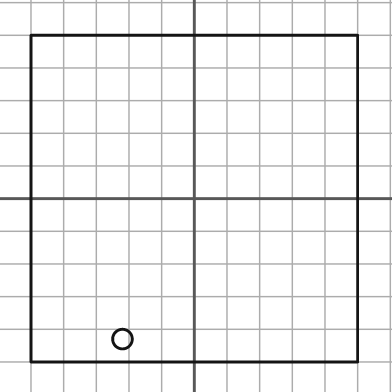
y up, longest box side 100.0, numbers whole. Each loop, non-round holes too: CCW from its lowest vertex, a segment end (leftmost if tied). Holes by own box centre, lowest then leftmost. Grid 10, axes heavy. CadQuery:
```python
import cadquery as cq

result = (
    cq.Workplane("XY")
    .moveTo(-50.0, -50.0)
    .lineTo(50.0, -50.0)
    .lineTo(50.0, 50.0)
    .lineTo(-50.0, 50.0)
    .close()
    .moveTo(-22.0, -43.0)
    .circle(3.0)
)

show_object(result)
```